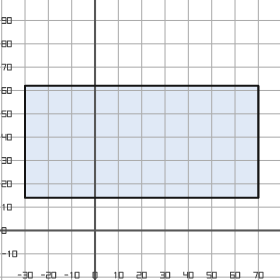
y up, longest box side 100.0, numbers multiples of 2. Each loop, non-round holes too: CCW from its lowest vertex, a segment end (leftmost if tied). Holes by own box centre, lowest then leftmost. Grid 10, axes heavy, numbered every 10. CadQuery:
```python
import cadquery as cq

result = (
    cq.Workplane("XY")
    .moveTo(-30.0, 14.0)
    .lineTo(70.0, 14.0)
    .lineTo(70.0, 62.0)
    .lineTo(-30.0, 62.0)
    .close()
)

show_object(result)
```